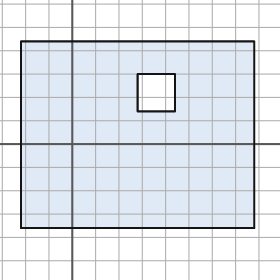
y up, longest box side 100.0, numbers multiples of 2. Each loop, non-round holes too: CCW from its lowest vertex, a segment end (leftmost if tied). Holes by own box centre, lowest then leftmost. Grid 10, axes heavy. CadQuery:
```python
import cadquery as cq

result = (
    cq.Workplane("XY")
    .moveTo(-22.0, -36.0)
    .lineTo(78.0, -36.0)
    .lineTo(78.0, 44.0)
    .lineTo(-22.0, 44.0)
    .close()
    .moveTo(28.0, 14.0)
    .lineTo(44.0, 14.0)
    .lineTo(44.0, 30.0)
    .lineTo(28.0, 30.0)
    .close()
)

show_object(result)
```